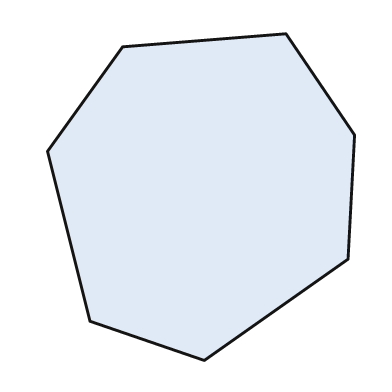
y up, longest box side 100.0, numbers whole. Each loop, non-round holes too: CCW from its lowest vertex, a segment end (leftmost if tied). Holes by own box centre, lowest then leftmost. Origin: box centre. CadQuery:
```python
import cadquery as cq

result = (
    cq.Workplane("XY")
    .moveTo(1.0, -50.0)
    .lineTo(45.0, -19.0)
    .lineTo(47.0, 19.0)
    .lineTo(26.0, 50.0)
    .lineTo(-24.0, 46.0)
    .lineTo(-47.0, 14.0)
    .lineTo(-34.0, -38.0)
    .close()
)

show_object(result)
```